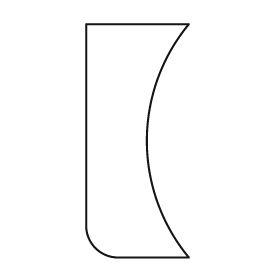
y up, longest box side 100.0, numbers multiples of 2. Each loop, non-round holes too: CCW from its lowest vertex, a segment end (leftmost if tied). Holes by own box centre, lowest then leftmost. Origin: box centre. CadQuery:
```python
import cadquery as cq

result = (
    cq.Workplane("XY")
    .moveTo(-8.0, -50.0)
    .lineTo(22.0, -50.0)
    .threePointArc((4.0, 0.0), (22.0, 50.0))
    .lineTo(-22.0, 50.0)
    .lineTo(-22.0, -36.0)
    .threePointArc((-18.0, -46.0), (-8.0, -50.0))
    .close()
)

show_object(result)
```